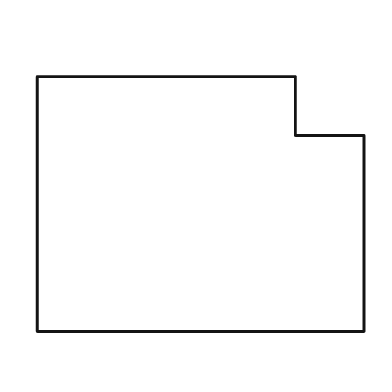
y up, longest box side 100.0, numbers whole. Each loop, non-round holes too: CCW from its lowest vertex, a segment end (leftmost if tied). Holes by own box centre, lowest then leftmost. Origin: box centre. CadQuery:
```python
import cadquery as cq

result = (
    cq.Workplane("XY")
    .moveTo(-50.0, -39.0)
    .lineTo(50.0, -39.0)
    .lineTo(50.0, 21.0)
    .lineTo(29.0, 21.0)
    .lineTo(29.0, 39.0)
    .lineTo(-50.0, 39.0)
    .close()
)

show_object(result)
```